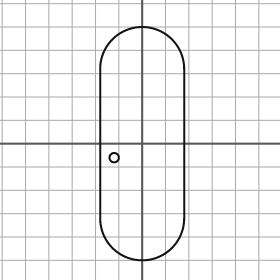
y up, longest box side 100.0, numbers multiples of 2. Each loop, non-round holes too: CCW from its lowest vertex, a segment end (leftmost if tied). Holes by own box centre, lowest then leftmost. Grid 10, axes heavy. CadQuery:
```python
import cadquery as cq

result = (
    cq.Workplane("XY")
    .moveTo(-18.0, -32.0)
    .threePointArc((0.0, -50.0), (18.0, -32.0))
    .lineTo(18.0, 32.0)
    .threePointArc((0.0, 50.0), (-18.0, 32.0))
    .close()
    .moveTo(-12.0, -6.0)
    .circle(2.0)
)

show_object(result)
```